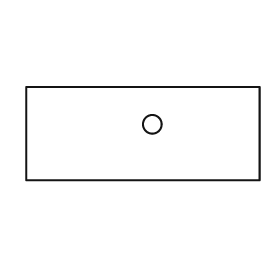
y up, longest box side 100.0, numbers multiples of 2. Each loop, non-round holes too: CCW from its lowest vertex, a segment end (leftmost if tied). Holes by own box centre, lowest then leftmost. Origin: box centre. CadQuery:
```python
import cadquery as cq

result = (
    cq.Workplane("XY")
    .moveTo(-50.0, -20.0)
    .lineTo(50.0, -20.0)
    .lineTo(50.0, 20.0)
    .lineTo(-50.0, 20.0)
    .close()
    .moveTo(4.0, 4.0)
    .circle(4.0)
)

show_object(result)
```